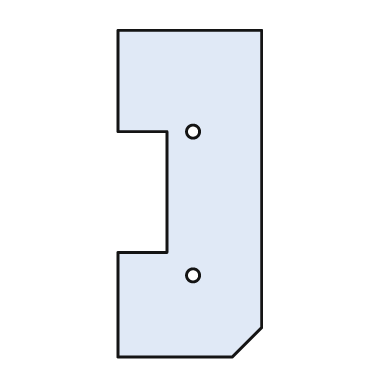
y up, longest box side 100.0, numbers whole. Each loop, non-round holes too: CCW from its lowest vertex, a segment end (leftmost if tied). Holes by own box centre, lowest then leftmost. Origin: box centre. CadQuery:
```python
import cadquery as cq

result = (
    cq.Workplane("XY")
    .moveTo(-22.0, -50.0)
    .lineTo(13.0, -50.0)
    .lineTo(22.0, -41.0)
    .lineTo(22.0, 50.0)
    .lineTo(-22.0, 50.0)
    .lineTo(-22.0, 19.0)
    .lineTo(-7.0, 19.0)
    .lineTo(-7.0, -18.0)
    .lineTo(-22.0, -18.0)
    .close()
    .moveTo(1.0, -25.0)
    .circle(2.0)
    .moveTo(1.0, 19.0)
    .circle(2.0)
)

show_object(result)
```